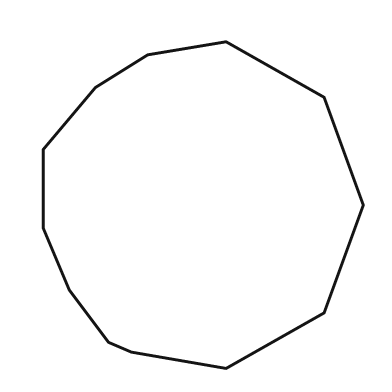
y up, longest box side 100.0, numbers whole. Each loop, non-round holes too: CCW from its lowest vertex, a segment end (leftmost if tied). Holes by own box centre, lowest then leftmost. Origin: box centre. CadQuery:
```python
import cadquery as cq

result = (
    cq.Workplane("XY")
    .moveTo(7.0, -50.0)
    .lineTo(37.0, -33.0)
    .lineTo(49.0, 0.0)
    .lineTo(37.0, 33.0)
    .lineTo(7.0, 50.0)
    .lineTo(-17.0, 46.0)
    .lineTo(-33.0, 36.0)
    .lineTo(-49.0, 17.0)
    .lineTo(-49.0, -7.0)
    .lineTo(-41.0, -26.0)
    .lineTo(-29.0, -42.0)
    .lineTo(-22.0, -45.0)
    .close()
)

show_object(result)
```